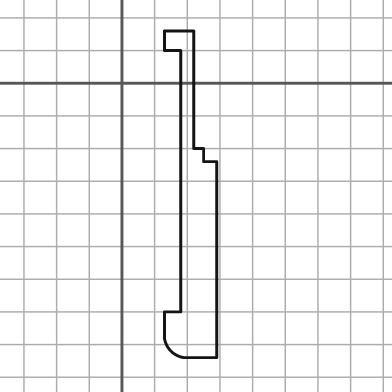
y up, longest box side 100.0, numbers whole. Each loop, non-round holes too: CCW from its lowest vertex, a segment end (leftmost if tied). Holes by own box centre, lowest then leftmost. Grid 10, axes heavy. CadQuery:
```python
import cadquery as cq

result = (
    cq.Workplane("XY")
    .moveTo(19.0, -84.0)
    .lineTo(29.0, -84.0)
    .lineTo(29.0, -24.0)
    .lineTo(25.0, -24.0)
    .lineTo(25.0, -20.0)
    .lineTo(22.0, -20.0)
    .lineTo(22.0, 16.0)
    .lineTo(13.0, 16.0)
    .lineTo(13.0, 10.0)
    .lineTo(18.0, 10.0)
    .lineTo(18.0, -70.0)
    .lineTo(13.0, -70.0)
    .lineTo(13.0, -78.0)
    .threePointArc((15.0, -82.0), (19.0, -84.0))
    .close()
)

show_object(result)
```